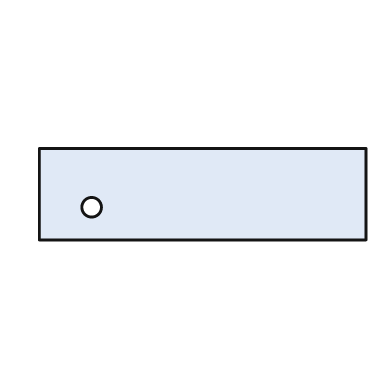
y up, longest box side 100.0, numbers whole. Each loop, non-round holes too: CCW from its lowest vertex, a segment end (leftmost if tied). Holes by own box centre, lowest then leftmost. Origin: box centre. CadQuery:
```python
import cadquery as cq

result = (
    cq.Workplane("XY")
    .moveTo(-50.0, -14.0)
    .lineTo(50.0, -14.0)
    .lineTo(50.0, 14.0)
    .lineTo(-50.0, 14.0)
    .close()
    .moveTo(-34.0, -4.0)
    .circle(3.0)
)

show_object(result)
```